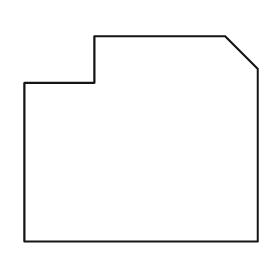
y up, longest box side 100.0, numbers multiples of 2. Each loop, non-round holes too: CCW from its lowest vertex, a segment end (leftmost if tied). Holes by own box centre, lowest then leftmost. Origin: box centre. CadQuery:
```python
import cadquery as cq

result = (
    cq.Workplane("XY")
    .moveTo(-50.0, -44.0)
    .lineTo(50.0, -44.0)
    .lineTo(50.0, 30.0)
    .lineTo(36.0, 44.0)
    .lineTo(-20.0, 44.0)
    .lineTo(-20.0, 24.0)
    .lineTo(-50.0, 24.0)
    .close()
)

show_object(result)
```